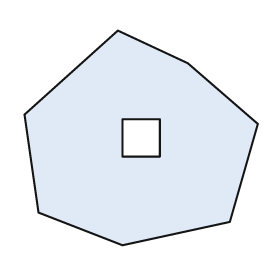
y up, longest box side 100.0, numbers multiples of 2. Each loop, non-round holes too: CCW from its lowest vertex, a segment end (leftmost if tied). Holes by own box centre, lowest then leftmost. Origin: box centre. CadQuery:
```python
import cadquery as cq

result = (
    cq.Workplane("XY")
    .moveTo(-8.0, -46.0)
    .lineTo(38.0, -36.0)
    .lineTo(50.0, 6.0)
    .lineTo(20.0, 32.0)
    .lineTo(-10.0, 46.0)
    .lineTo(-50.0, 10.0)
    .lineTo(-44.0, -32.0)
    .close()
    .moveTo(-8.0, -8.0)
    .lineTo(8.0, -8.0)
    .lineTo(8.0, 8.0)
    .lineTo(-8.0, 8.0)
    .close()
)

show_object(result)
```